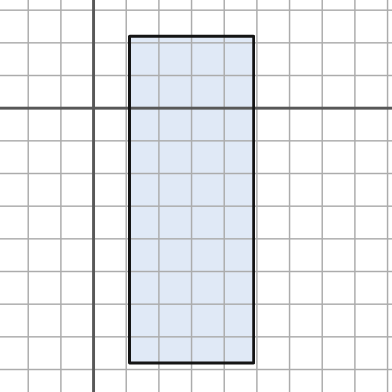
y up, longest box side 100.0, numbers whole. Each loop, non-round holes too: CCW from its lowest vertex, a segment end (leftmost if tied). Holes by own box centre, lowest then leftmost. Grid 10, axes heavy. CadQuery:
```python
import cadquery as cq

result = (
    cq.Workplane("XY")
    .moveTo(11.0, -78.0)
    .lineTo(49.0, -78.0)
    .lineTo(49.0, 22.0)
    .lineTo(11.0, 22.0)
    .close()
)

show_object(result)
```